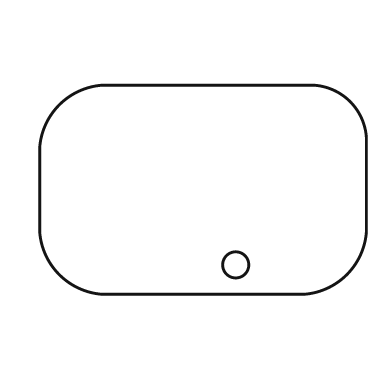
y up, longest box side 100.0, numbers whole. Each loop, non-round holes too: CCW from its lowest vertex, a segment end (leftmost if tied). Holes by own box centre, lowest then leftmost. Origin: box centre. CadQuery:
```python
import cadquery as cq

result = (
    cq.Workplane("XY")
    .moveTo(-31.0, -32.0)
    .lineTo(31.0, -32.0)
    .threePointArc((44.0, -26.0), (50.0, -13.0))
    .lineTo(50.0, 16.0)
    .threePointArc((45.0, 27.0), (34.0, 32.0))
    .lineTo(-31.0, 32.0)
    .threePointArc((-44.0, 26.0), (-50.0, 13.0))
    .lineTo(-50.0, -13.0)
    .threePointArc((-44.0, -26.0), (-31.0, -32.0))
    .close()
    .moveTo(10.0, -23.0)
    .circle(4.0)
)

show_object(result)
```